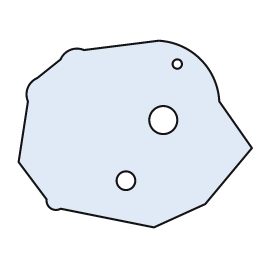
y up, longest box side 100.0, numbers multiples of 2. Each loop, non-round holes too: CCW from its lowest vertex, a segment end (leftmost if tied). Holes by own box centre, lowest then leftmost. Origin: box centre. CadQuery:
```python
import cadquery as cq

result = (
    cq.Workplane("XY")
    .moveTo(8.0, -40.0)
    .lineTo(30.0, -30.0)
    .lineTo(50.0, -6.0)
    .lineTo(36.0, 14.0)
    .threePointArc((28.0, 32.0), (10.0, 40.0))
    .lineTo(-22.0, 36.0)
    .threePointArc((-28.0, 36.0), (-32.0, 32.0))
    .lineTo(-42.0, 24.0)
    .threePointArc((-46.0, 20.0), (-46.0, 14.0))
    .lineTo(-50.0, -12.0)
    .lineTo(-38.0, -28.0)
    .threePointArc((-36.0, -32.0), (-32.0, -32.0))
    .close()
    .moveTo(-4.0, -20.0)
    .circle(4.0)
    .moveTo(12.0, 6.0)
    .circle(6.0)
    .moveTo(18.0, 30.0)
    .circle(2.0)
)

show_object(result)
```